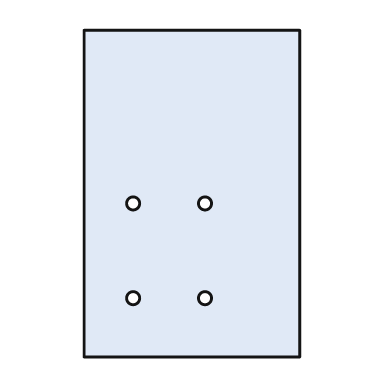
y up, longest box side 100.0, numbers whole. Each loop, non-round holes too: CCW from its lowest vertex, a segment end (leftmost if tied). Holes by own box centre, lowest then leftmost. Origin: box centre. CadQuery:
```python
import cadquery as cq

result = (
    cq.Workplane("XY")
    .moveTo(-33.0, -50.0)
    .lineTo(33.0, -50.0)
    .lineTo(33.0, 50.0)
    .lineTo(-33.0, 50.0)
    .close()
    .moveTo(-18.0, -32.0)
    .circle(2.0)
    .moveTo(4.0, -32.0)
    .circle(2.0)
    .moveTo(-18.0, -3.0)
    .circle(2.0)
    .moveTo(4.0, -3.0)
    .circle(2.0)
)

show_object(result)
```